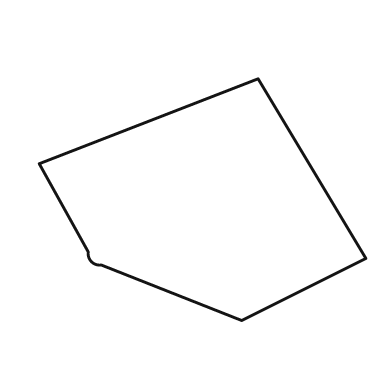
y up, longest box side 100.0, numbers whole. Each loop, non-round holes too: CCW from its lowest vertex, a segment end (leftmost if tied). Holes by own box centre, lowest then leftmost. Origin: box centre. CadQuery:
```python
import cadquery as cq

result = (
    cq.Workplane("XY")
    .moveTo(12.0, -37.0)
    .lineTo(50.0, -18.0)
    .lineTo(17.0, 37.0)
    .lineTo(-50.0, 11.0)
    .lineTo(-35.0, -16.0)
    .threePointArc((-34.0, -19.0), (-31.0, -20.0))
    .close()
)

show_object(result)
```